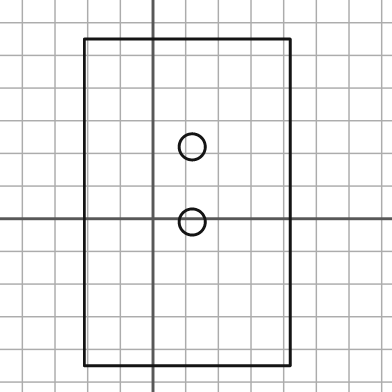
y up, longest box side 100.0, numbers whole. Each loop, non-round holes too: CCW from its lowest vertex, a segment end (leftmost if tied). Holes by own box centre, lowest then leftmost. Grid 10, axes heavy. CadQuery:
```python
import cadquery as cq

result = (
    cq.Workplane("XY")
    .moveTo(-21.0, -45.0)
    .lineTo(42.0, -45.0)
    .lineTo(42.0, 55.0)
    .lineTo(-21.0, 55.0)
    .close()
    .moveTo(12.0, -1.0)
    .circle(4.0)
    .moveTo(12.0, 22.0)
    .circle(4.0)
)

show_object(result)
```